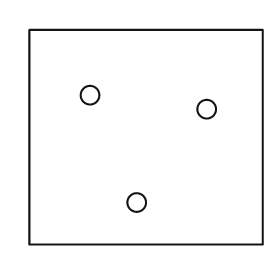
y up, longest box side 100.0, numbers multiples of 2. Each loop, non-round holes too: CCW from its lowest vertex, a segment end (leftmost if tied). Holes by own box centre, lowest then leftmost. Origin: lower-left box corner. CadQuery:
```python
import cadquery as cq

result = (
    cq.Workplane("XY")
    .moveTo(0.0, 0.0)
    .lineTo(100.0, 0.0)
    .lineTo(100.0, 92.0)
    .lineTo(0.0, 92.0)
    .close()
    .moveTo(46.0, 18.0)
    .circle(4.0)
    .moveTo(76.0, 58.0)
    .circle(4.0)
    .moveTo(26.0, 64.0)
    .circle(4.0)
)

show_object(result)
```